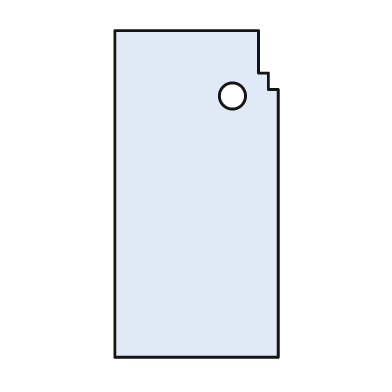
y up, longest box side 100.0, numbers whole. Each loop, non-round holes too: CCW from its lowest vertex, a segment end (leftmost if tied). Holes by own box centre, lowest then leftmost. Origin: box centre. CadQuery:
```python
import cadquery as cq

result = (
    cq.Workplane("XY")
    .moveTo(-25.0, -50.0)
    .lineTo(25.0, -50.0)
    .lineTo(25.0, 32.0)
    .lineTo(22.0, 32.0)
    .lineTo(22.0, 37.0)
    .lineTo(19.0, 37.0)
    .lineTo(19.0, 50.0)
    .lineTo(-25.0, 50.0)
    .close()
    .moveTo(11.0, 30.0)
    .circle(4.0)
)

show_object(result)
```